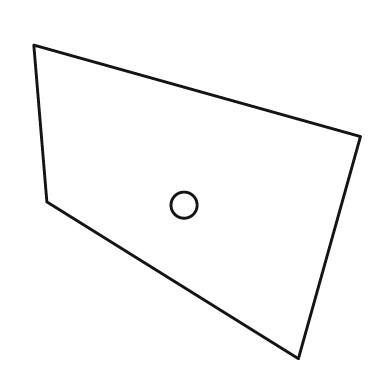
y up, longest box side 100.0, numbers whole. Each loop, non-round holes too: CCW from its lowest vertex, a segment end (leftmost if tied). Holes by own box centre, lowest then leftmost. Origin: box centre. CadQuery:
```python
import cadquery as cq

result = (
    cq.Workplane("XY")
    .moveTo(31.0, -48.0)
    .lineTo(50.0, 20.0)
    .lineTo(-50.0, 48.0)
    .lineTo(-46.0, 0.0)
    .close()
    .moveTo(-4.0, -1.0)
    .circle(4.0)
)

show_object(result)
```